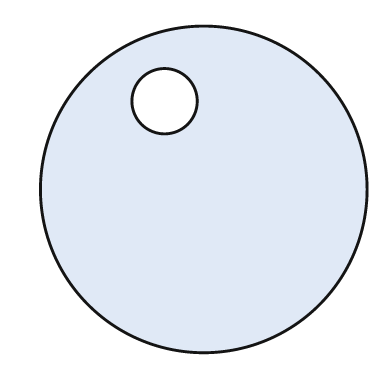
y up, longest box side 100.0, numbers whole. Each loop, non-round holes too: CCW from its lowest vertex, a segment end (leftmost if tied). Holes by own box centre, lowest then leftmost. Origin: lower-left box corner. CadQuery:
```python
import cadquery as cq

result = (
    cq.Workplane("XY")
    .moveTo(50.0, 50.0)
    .circle(50.0)
    .moveTo(38.0, 77.0)
    .circle(10.0)
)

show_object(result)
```